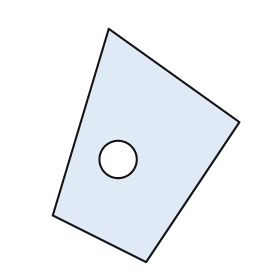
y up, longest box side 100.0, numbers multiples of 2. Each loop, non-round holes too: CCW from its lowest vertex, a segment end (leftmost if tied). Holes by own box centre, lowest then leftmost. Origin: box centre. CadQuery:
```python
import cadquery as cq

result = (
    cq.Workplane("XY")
    .moveTo(0.0, -50.0)
    .lineTo(40.0, 10.0)
    .lineTo(-16.0, 50.0)
    .lineTo(-40.0, -30.0)
    .close()
    .moveTo(-12.0, -6.0)
    .circle(8.0)
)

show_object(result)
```